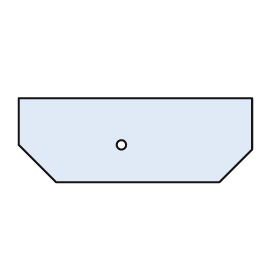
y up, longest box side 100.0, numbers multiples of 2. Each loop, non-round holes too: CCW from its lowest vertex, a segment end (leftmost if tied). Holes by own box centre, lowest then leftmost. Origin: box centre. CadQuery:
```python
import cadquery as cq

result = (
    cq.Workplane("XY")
    .moveTo(-34.0, -18.0)
    .lineTo(36.0, -18.0)
    .lineTo(50.0, -4.0)
    .lineTo(50.0, 18.0)
    .lineTo(-50.0, 18.0)
    .lineTo(-50.0, -2.0)
    .close()
    .moveTo(-6.0, -2.0)
    .circle(2.0)
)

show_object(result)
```